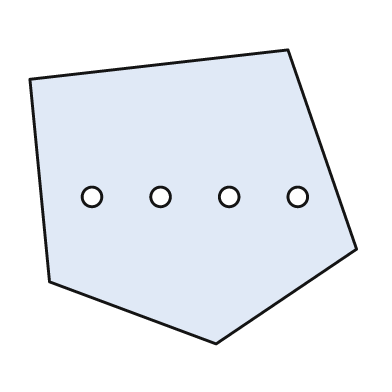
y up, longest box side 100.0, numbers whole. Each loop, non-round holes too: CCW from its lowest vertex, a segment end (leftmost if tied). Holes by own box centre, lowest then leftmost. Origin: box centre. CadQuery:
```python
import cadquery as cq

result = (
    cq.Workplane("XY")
    .moveTo(7.0, -45.0)
    .lineTo(50.0, -16.0)
    .lineTo(29.0, 45.0)
    .lineTo(-50.0, 36.0)
    .lineTo(-44.0, -26.0)
    .close()
    .moveTo(-31.0, 0.0)
    .circle(3.0)
    .moveTo(-10.0, 0.0)
    .circle(3.0)
    .moveTo(11.0, 0.0)
    .circle(3.0)
    .moveTo(32.0, 0.0)
    .circle(3.0)
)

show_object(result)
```